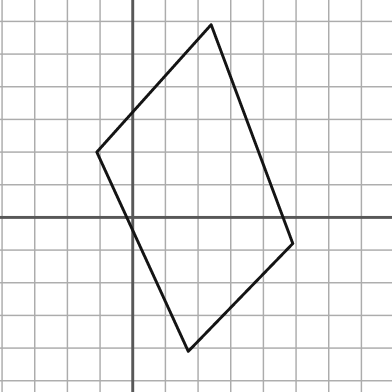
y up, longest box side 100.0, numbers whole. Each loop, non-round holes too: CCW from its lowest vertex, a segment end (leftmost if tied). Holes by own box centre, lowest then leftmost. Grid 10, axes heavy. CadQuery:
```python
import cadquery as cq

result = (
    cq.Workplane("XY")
    .moveTo(17.0, -41.0)
    .lineTo(49.0, -8.0)
    .lineTo(24.0, 59.0)
    .lineTo(-11.0, 20.0)
    .close()
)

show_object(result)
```